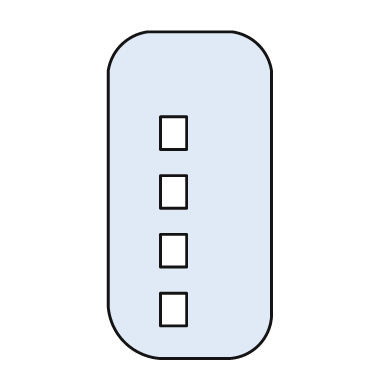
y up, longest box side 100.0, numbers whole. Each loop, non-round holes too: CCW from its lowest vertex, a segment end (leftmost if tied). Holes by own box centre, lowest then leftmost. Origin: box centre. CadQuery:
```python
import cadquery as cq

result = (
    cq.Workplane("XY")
    .moveTo(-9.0, -50.0)
    .lineTo(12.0, -50.0)
    .threePointArc((21.0, -46.0), (25.0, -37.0))
    .lineTo(25.0, 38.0)
    .threePointArc((21.0, 46.0), (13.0, 50.0))
    .lineTo(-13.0, 50.0)
    .threePointArc((-21.0, 46.0), (-25.0, 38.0))
    .lineTo(-25.0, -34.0)
    .threePointArc((-20.0, -45.0), (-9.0, -50.0))
    .close()
    .moveTo(-9.0, -40.0)
    .lineTo(-1.0, -40.0)
    .lineTo(-1.0, -30.0)
    .lineTo(-9.0, -30.0)
    .close()
    .moveTo(-9.0, -22.0)
    .lineTo(-1.0, -22.0)
    .lineTo(-1.0, -12.0)
    .lineTo(-9.0, -12.0)
    .close()
    .moveTo(-9.0, -4.0)
    .lineTo(-1.0, -4.0)
    .lineTo(-1.0, 6.0)
    .lineTo(-9.0, 6.0)
    .close()
    .moveTo(-9.0, 14.0)
    .lineTo(-1.0, 14.0)
    .lineTo(-1.0, 24.0)
    .lineTo(-9.0, 24.0)
    .close()
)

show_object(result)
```